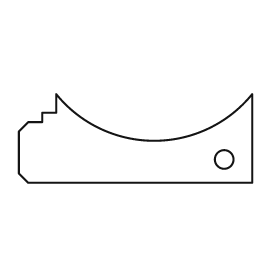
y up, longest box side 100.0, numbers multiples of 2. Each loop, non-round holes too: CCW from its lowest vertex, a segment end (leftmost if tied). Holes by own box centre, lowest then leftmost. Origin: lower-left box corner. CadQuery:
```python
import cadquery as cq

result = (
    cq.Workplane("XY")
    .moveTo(4.0, 0.0)
    .lineTo(100.0, 0.0)
    .lineTo(100.0, 38.0)
    .threePointArc((58.0, 18.0), (16.0, 38.0))
    .lineTo(16.0, 30.0)
    .lineTo(10.0, 30.0)
    .lineTo(10.0, 26.0)
    .lineTo(4.0, 26.0)
    .lineTo(0.0, 22.0)
    .lineTo(0.0, 4.0)
    .close()
    .moveTo(88.0, 10.0)
    .circle(4.0)
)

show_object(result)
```